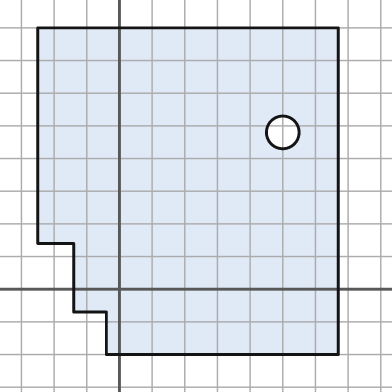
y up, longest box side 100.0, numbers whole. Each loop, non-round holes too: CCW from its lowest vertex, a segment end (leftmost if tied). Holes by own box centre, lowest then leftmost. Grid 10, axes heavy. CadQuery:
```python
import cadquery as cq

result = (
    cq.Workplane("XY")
    .moveTo(-4.0, -20.0)
    .lineTo(67.0, -20.0)
    .lineTo(67.0, 80.0)
    .lineTo(-25.0, 80.0)
    .lineTo(-25.0, 14.0)
    .lineTo(-14.0, 14.0)
    .lineTo(-14.0, -7.0)
    .lineTo(-4.0, -7.0)
    .close()
    .moveTo(50.0, 48.0)
    .circle(5.0)
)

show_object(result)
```